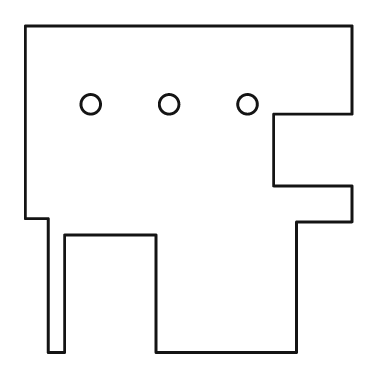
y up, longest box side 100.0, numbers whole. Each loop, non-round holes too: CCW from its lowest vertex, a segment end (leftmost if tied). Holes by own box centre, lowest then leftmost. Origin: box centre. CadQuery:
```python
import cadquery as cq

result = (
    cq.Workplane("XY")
    .moveTo(-43.0, -50.0)
    .lineTo(-38.0, -50.0)
    .lineTo(-38.0, -14.0)
    .lineTo(-10.0, -14.0)
    .lineTo(-10.0, -50.0)
    .lineTo(33.0, -50.0)
    .lineTo(33.0, -10.0)
    .lineTo(50.0, -10.0)
    .lineTo(50.0, 1.0)
    .lineTo(26.0, 1.0)
    .lineTo(26.0, 23.0)
    .lineTo(50.0, 23.0)
    .lineTo(50.0, 50.0)
    .lineTo(-50.0, 50.0)
    .lineTo(-50.0, -9.0)
    .lineTo(-43.0, -9.0)
    .close()
    .moveTo(-30.0, 26.0)
    .circle(3.0)
    .moveTo(-6.0, 26.0)
    .circle(3.0)
    .moveTo(18.0, 26.0)
    .circle(3.0)
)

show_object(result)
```